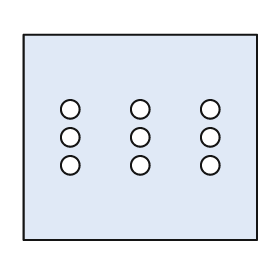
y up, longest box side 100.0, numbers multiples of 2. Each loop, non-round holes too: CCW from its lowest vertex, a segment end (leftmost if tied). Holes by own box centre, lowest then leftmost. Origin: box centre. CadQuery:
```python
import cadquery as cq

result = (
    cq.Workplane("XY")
    .moveTo(-50.0, -44.0)
    .lineTo(50.0, -44.0)
    .lineTo(50.0, 44.0)
    .lineTo(-50.0, 44.0)
    .close()
    .moveTo(-30.0, -12.0)
    .circle(4.0)
    .moveTo(0.0, -12.0)
    .circle(4.0)
    .moveTo(30.0, -12.0)
    .circle(4.0)
    .moveTo(-30.0, 0.0)
    .circle(4.0)
    .moveTo(0.0, 0.0)
    .circle(4.0)
    .moveTo(30.0, 0.0)
    .circle(4.0)
    .moveTo(-30.0, 12.0)
    .circle(4.0)
    .moveTo(0.0, 12.0)
    .circle(4.0)
    .moveTo(30.0, 12.0)
    .circle(4.0)
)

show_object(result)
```